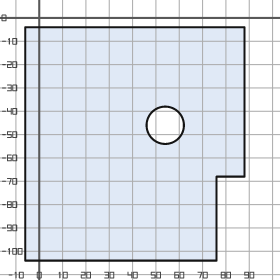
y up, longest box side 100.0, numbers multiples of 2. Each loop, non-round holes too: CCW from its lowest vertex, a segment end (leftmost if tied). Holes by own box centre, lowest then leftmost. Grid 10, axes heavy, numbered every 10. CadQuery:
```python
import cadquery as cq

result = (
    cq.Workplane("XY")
    .moveTo(-6.0, -104.0)
    .lineTo(76.0, -104.0)
    .lineTo(76.0, -68.0)
    .lineTo(88.0, -68.0)
    .lineTo(88.0, -4.0)
    .lineTo(-6.0, -4.0)
    .close()
    .moveTo(54.0, -46.0)
    .circle(8.0)
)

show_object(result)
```